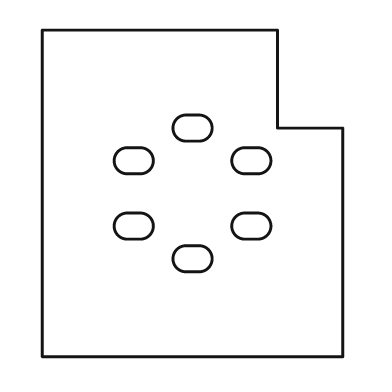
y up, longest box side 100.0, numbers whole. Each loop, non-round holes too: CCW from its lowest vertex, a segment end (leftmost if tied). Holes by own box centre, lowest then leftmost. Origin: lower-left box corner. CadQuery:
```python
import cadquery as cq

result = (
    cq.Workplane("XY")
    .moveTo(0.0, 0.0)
    .lineTo(92.0, 0.0)
    .lineTo(92.0, 70.0)
    .lineTo(72.0, 70.0)
    .lineTo(72.0, 100.0)
    .lineTo(0.0, 100.0)
    .close()
    .moveTo(44.0, 26.0)
    .lineTo(48.0, 26.0)
    .threePointArc((52.0, 30.0), (48.0, 34.0))
    .lineTo(44.0, 34.0)
    .threePointArc((40.0, 30.0), (44.0, 26.0))
    .close()
    .moveTo(26.0, 36.0)
    .lineTo(30.0, 36.0)
    .threePointArc((34.0, 40.0), (30.0, 44.0))
    .lineTo(26.0, 44.0)
    .threePointArc((22.0, 40.0), (26.0, 36.0))
    .close()
    .moveTo(62.0, 36.0)
    .lineTo(66.0, 36.0)
    .threePointArc((70.0, 40.0), (66.0, 44.0))
    .lineTo(62.0, 44.0)
    .threePointArc((58.0, 40.0), (62.0, 36.0))
    .close()
    .moveTo(26.0, 56.0)
    .lineTo(30.0, 56.0)
    .threePointArc((34.0, 60.0), (30.0, 64.0))
    .lineTo(26.0, 64.0)
    .threePointArc((22.0, 60.0), (26.0, 56.0))
    .close()
    .moveTo(62.0, 56.0)
    .lineTo(66.0, 56.0)
    .threePointArc((70.0, 60.0), (66.0, 64.0))
    .lineTo(62.0, 64.0)
    .threePointArc((58.0, 60.0), (62.0, 56.0))
    .close()
    .moveTo(44.0, 66.0)
    .lineTo(48.0, 66.0)
    .threePointArc((52.0, 70.0), (48.0, 74.0))
    .lineTo(44.0, 74.0)
    .threePointArc((40.0, 70.0), (44.0, 66.0))
    .close()
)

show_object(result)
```